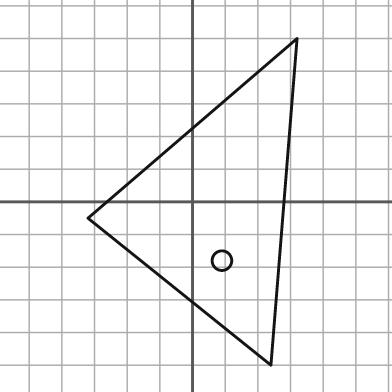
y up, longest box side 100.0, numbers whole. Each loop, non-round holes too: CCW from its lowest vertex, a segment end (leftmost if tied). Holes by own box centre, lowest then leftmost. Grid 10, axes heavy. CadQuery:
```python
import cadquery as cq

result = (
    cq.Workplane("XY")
    .moveTo(24.0, -50.0)
    .lineTo(32.0, 50.0)
    .lineTo(-32.0, -5.0)
    .close()
    .moveTo(9.0, -18.0)
    .circle(3.0)
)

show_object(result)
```